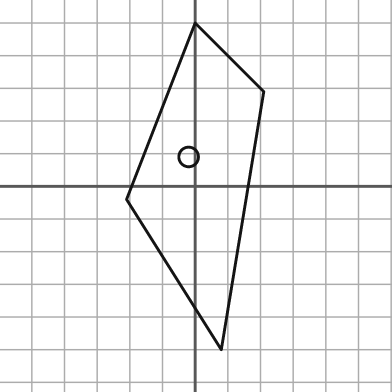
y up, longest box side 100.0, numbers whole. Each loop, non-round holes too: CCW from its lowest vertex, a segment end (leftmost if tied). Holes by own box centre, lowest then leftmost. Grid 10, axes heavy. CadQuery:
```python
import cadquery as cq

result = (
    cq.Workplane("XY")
    .moveTo(8.0, -50.0)
    .lineTo(21.0, 29.0)
    .lineTo(0.0, 50.0)
    .lineTo(-21.0, -4.0)
    .close()
    .moveTo(-2.0, 9.0)
    .circle(3.0)
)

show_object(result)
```